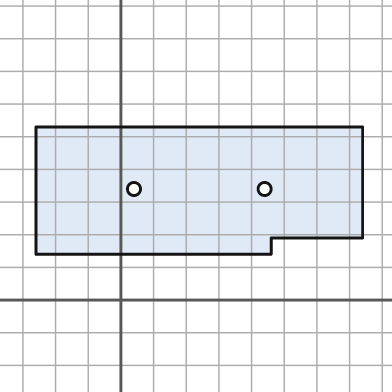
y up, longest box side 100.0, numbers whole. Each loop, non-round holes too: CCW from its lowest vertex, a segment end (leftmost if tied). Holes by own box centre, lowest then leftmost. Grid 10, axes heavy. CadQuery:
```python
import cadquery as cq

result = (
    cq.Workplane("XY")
    .moveTo(-26.0, 14.0)
    .lineTo(46.0, 14.0)
    .lineTo(46.0, 19.0)
    .lineTo(74.0, 19.0)
    .lineTo(74.0, 53.0)
    .lineTo(-26.0, 53.0)
    .close()
    .moveTo(4.0, 34.0)
    .circle(2.0)
    .moveTo(44.0, 34.0)
    .circle(2.0)
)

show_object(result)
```